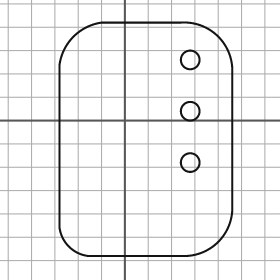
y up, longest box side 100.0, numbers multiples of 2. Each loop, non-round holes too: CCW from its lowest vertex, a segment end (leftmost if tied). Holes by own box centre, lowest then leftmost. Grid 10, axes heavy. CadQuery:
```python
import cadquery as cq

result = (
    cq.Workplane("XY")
    .moveTo(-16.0, -58.0)
    .lineTo(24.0, -58.0)
    .threePointArc((40.0, -52.0), (46.0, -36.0))
    .lineTo(46.0, 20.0)
    .threePointArc((40.0, 36.0), (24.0, 42.0))
    .lineTo(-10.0, 42.0)
    .threePointArc((-22.0, 36.0), (-28.0, 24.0))
    .lineTo(-28.0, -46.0)
    .threePointArc((-24.0, -54.0), (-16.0, -58.0))
    .close()
    .moveTo(28.0, -18.0)
    .circle(4.0)
    .moveTo(28.0, 4.0)
    .circle(4.0)
    .moveTo(28.0, 26.0)
    .circle(4.0)
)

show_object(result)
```